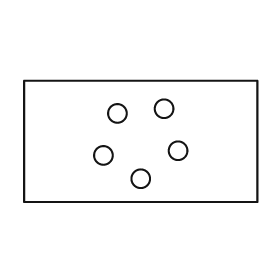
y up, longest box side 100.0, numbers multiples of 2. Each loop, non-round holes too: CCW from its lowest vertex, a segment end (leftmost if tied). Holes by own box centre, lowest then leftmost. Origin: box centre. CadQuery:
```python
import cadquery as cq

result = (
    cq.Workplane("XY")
    .moveTo(-50.0, -26.0)
    .lineTo(50.0, -26.0)
    .lineTo(50.0, 26.0)
    .lineTo(-50.0, 26.0)
    .close()
    .moveTo(0.0, -16.0)
    .circle(4.0)
    .moveTo(-16.0, -6.0)
    .circle(4.0)
    .moveTo(16.0, -4.0)
    .circle(4.0)
    .moveTo(-10.0, 12.0)
    .circle(4.0)
    .moveTo(10.0, 14.0)
    .circle(4.0)
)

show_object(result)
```